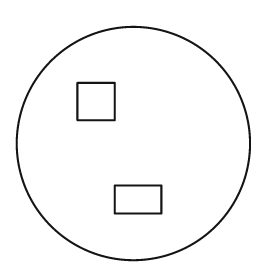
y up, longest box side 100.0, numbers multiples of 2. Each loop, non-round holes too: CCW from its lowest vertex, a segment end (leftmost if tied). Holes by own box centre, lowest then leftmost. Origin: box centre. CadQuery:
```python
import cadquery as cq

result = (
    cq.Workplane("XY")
    .moveTo(0.0, 0.0)
    .circle(50.0)
    .moveTo(-8.0, -30.0)
    .lineTo(12.0, -30.0)
    .lineTo(12.0, -18.0)
    .lineTo(-8.0, -18.0)
    .close()
    .moveTo(-24.0, 10.0)
    .lineTo(-8.0, 10.0)
    .lineTo(-8.0, 26.0)
    .lineTo(-24.0, 26.0)
    .close()
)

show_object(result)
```